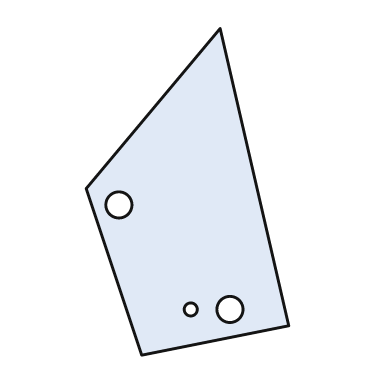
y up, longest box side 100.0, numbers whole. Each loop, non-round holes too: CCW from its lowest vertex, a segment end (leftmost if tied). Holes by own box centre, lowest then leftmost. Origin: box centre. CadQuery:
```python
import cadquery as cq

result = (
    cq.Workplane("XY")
    .moveTo(-14.0, -50.0)
    .lineTo(31.0, -41.0)
    .lineTo(10.0, 50.0)
    .lineTo(-31.0, 1.0)
    .close()
    .moveTo(1.0, -36.0)
    .circle(2.0)
    .moveTo(13.0, -36.0)
    .circle(4.0)
    .moveTo(-21.0, -4.0)
    .circle(4.0)
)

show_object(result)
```